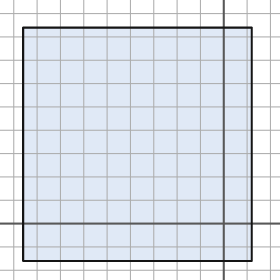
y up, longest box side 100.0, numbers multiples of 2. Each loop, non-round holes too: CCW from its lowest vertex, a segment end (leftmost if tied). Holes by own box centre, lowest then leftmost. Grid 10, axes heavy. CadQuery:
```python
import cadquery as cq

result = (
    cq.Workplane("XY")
    .moveTo(-86.0, -16.0)
    .lineTo(12.0, -16.0)
    .lineTo(12.0, 84.0)
    .lineTo(-86.0, 84.0)
    .close()
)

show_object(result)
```